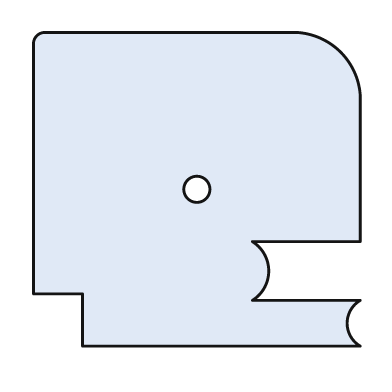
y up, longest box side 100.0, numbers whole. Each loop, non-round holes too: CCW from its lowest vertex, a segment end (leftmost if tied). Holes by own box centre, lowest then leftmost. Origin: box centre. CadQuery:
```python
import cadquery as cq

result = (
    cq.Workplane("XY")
    .moveTo(-35.0, -48.0)
    .lineTo(50.0, -48.0)
    .threePointArc((46.0, -41.0), (50.0, -34.0))
    .lineTo(17.0, -34.0)
    .threePointArc((22.0, -25.0), (17.0, -16.0))
    .lineTo(50.0, -16.0)
    .lineTo(50.0, 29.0)
    .threePointArc((44.0, 42.0), (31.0, 48.0))
    .lineTo(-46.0, 48.0)
    .threePointArc((-49.0, 47.0), (-50.0, 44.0))
    .lineTo(-50.0, -32.0)
    .lineTo(-35.0, -32.0)
    .close()
    .moveTo(0.0, 0.0)
    .circle(4.0)
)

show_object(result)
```